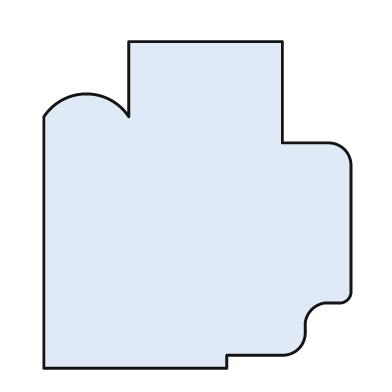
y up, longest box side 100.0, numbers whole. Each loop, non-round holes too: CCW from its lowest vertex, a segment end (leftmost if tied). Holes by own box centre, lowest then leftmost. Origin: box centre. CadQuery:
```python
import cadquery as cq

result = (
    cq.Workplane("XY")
    .moveTo(-47.0, -50.0)
    .lineTo(9.0, -50.0)
    .lineTo(9.0, -46.0)
    .lineTo(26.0, -46.0)
    .threePointArc((31.0, -44.0), (33.0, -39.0))
    .lineTo(33.0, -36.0)
    .threePointArc((35.0, -32.0), (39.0, -30.0))
    .lineTo(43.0, -30.0)
    .threePointArc((46.0, -29.0), (47.0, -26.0))
    .lineTo(47.0, 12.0)
    .threePointArc((45.0, 17.0), (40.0, 19.0))
    .lineTo(26.0, 19.0)
    .lineTo(26.0, 50.0)
    .lineTo(-21.0, 50.0)
    .lineTo(-21.0, 27.0)
    .threePointArc((-34.0, 34.0), (-47.0, 27.0))
    .close()
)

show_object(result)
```